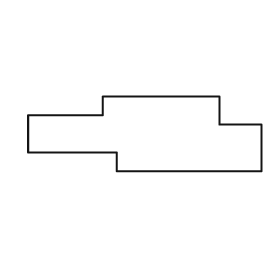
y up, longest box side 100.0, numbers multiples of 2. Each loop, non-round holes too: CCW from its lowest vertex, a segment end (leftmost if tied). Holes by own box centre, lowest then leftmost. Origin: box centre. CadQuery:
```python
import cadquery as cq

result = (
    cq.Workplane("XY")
    .moveTo(-12.0, -16.0)
    .lineTo(50.0, -16.0)
    .lineTo(50.0, 4.0)
    .lineTo(32.0, 4.0)
    .lineTo(32.0, 16.0)
    .lineTo(-18.0, 16.0)
    .lineTo(-18.0, 8.0)
    .lineTo(-50.0, 8.0)
    .lineTo(-50.0, -8.0)
    .lineTo(-12.0, -8.0)
    .close()
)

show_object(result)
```